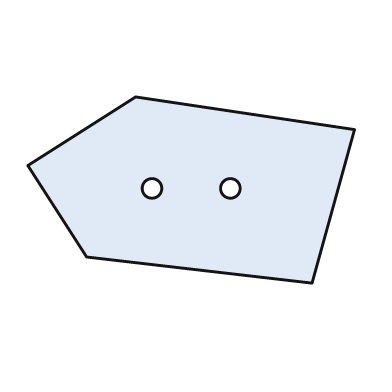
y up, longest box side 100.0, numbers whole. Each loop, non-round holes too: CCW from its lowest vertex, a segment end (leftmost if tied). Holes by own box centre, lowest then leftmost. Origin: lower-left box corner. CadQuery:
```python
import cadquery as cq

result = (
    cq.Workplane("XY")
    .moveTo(87.0, 0.0)
    .lineTo(100.0, 47.0)
    .lineTo(33.0, 57.0)
    .lineTo(0.0, 36.0)
    .lineTo(18.0, 8.0)
    .close()
    .moveTo(38.0, 29.0)
    .circle(3.0)
    .moveTo(62.0, 29.0)
    .circle(3.0)
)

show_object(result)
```